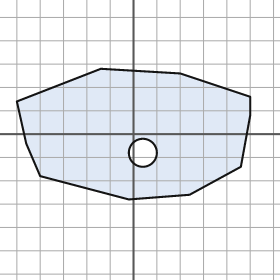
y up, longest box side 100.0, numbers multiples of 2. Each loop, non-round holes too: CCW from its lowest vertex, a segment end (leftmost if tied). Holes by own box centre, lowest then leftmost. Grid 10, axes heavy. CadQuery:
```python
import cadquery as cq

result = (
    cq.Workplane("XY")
    .moveTo(-2.0, -28.0)
    .lineTo(24.0, -26.0)
    .lineTo(46.0, -14.0)
    .lineTo(50.0, 8.0)
    .lineTo(50.0, 16.0)
    .lineTo(20.0, 26.0)
    .lineTo(-14.0, 28.0)
    .lineTo(-50.0, 14.0)
    .lineTo(-46.0, -4.0)
    .lineTo(-40.0, -18.0)
    .close()
    .moveTo(4.0, -8.0)
    .circle(6.0)
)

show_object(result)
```